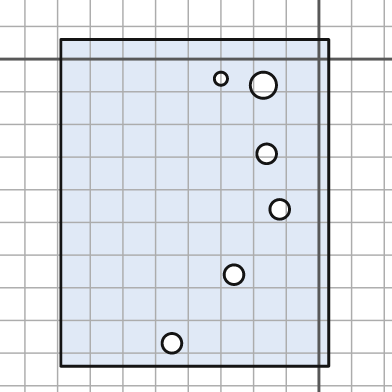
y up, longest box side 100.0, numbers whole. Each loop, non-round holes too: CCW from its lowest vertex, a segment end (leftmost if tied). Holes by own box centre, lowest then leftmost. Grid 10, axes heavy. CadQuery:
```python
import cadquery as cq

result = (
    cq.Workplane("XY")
    .moveTo(-79.0, -94.0)
    .lineTo(3.0, -94.0)
    .lineTo(3.0, 6.0)
    .lineTo(-79.0, 6.0)
    .close()
    .moveTo(-45.0, -87.0)
    .circle(3.0)
    .moveTo(-26.0, -66.0)
    .circle(3.0)
    .moveTo(-12.0, -46.0)
    .circle(3.0)
    .moveTo(-16.0, -29.0)
    .circle(3.0)
    .moveTo(-17.0, -8.0)
    .circle(4.0)
    .moveTo(-30.0, -6.0)
    .circle(2.0)
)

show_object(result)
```